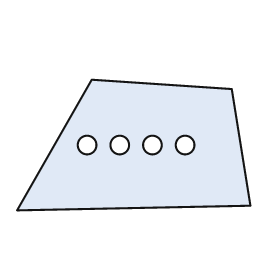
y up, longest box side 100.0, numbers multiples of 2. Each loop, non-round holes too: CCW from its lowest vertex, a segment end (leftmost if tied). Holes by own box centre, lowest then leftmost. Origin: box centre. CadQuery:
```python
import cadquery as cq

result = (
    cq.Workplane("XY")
    .moveTo(-50.0, -28.0)
    .lineTo(50.0, -26.0)
    .lineTo(42.0, 24.0)
    .lineTo(-18.0, 28.0)
    .close()
    .moveTo(-20.0, 0.0)
    .circle(4.0)
    .moveTo(-6.0, 0.0)
    .circle(4.0)
    .moveTo(8.0, 0.0)
    .circle(4.0)
    .moveTo(22.0, 0.0)
    .circle(4.0)
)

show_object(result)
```